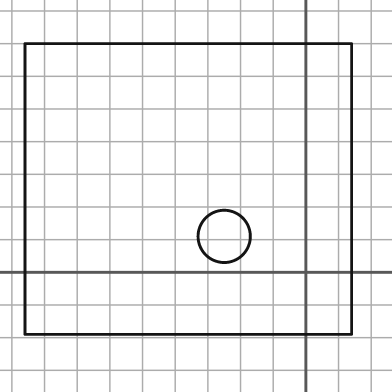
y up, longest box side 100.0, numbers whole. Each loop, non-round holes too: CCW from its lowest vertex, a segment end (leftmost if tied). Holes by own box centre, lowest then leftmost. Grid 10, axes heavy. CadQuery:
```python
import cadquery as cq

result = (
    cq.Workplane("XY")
    .moveTo(-86.0, -19.0)
    .lineTo(14.0, -19.0)
    .lineTo(14.0, 70.0)
    .lineTo(-86.0, 70.0)
    .close()
    .moveTo(-25.0, 11.0)
    .circle(8.0)
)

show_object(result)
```